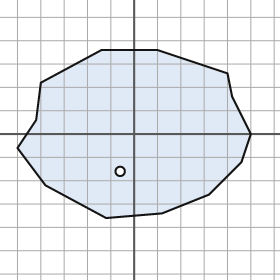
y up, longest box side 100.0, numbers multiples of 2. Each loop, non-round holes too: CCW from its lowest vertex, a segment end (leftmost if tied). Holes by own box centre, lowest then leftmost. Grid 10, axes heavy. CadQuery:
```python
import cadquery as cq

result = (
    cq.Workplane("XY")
    .moveTo(-12.0, -36.0)
    .lineTo(12.0, -34.0)
    .lineTo(32.0, -26.0)
    .lineTo(46.0, -12.0)
    .lineTo(50.0, 0.0)
    .lineTo(42.0, 16.0)
    .lineTo(40.0, 26.0)
    .lineTo(10.0, 36.0)
    .lineTo(-14.0, 36.0)
    .lineTo(-40.0, 22.0)
    .lineTo(-42.0, 6.0)
    .lineTo(-50.0, -6.0)
    .lineTo(-38.0, -22.0)
    .close()
    .moveTo(-6.0, -16.0)
    .circle(2.0)
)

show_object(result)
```